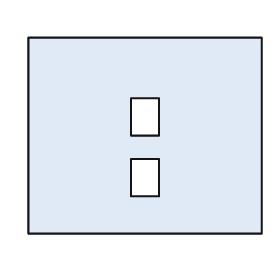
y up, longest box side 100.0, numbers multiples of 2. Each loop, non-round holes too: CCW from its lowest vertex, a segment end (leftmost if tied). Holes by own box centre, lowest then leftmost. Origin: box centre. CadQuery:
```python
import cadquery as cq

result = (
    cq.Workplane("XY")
    .moveTo(-50.0, -42.0)
    .lineTo(50.0, -42.0)
    .lineTo(50.0, 42.0)
    .lineTo(-50.0, 42.0)
    .close()
    .moveTo(-6.0, -26.0)
    .lineTo(6.0, -26.0)
    .lineTo(6.0, -10.0)
    .lineTo(-6.0, -10.0)
    .close()
    .moveTo(-6.0, 0.0)
    .lineTo(6.0, 0.0)
    .lineTo(6.0, 16.0)
    .lineTo(-6.0, 16.0)
    .close()
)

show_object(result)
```